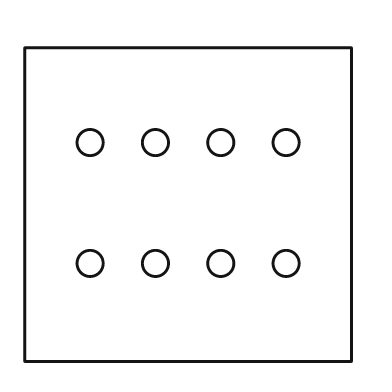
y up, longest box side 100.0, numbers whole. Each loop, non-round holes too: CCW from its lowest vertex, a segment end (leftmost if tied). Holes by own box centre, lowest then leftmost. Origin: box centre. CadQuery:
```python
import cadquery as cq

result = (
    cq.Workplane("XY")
    .moveTo(-50.0, -48.0)
    .lineTo(50.0, -48.0)
    .lineTo(50.0, 48.0)
    .lineTo(-50.0, 48.0)
    .close()
    .moveTo(-30.0, -18.0)
    .circle(4.0)
    .moveTo(-10.0, -18.0)
    .circle(4.0)
    .moveTo(10.0, -18.0)
    .circle(4.0)
    .moveTo(30.0, -18.0)
    .circle(4.0)
    .moveTo(-30.0, 19.0)
    .circle(4.0)
    .moveTo(-10.0, 19.0)
    .circle(4.0)
    .moveTo(10.0, 19.0)
    .circle(4.0)
    .moveTo(30.0, 19.0)
    .circle(4.0)
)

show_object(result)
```